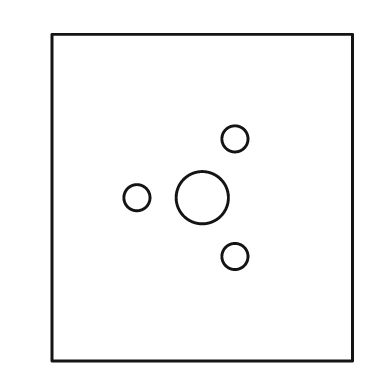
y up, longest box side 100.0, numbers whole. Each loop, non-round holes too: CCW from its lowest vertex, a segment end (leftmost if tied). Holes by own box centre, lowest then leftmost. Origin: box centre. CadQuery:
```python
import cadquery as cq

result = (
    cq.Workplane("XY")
    .moveTo(-46.0, -50.0)
    .lineTo(46.0, -50.0)
    .lineTo(46.0, 50.0)
    .lineTo(-46.0, 50.0)
    .close()
    .moveTo(10.0, -18.0)
    .circle(4.0)
    .moveTo(-20.0, 0.0)
    .circle(4.0)
    .moveTo(0.0, 0.0)
    .circle(8.0)
    .moveTo(10.0, 18.0)
    .circle(4.0)
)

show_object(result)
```